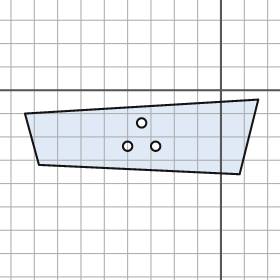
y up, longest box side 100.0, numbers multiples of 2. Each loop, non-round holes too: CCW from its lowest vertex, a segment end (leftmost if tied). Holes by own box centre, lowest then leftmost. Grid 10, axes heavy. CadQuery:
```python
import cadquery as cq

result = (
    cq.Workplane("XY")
    .moveTo(8.0, -36.0)
    .lineTo(16.0, -4.0)
    .lineTo(-84.0, -10.0)
    .lineTo(-78.0, -32.0)
    .close()
    .moveTo(-40.0, -24.0)
    .circle(2.0)
    .moveTo(-28.0, -24.0)
    .circle(2.0)
    .moveTo(-34.0, -14.0)
    .circle(2.0)
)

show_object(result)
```